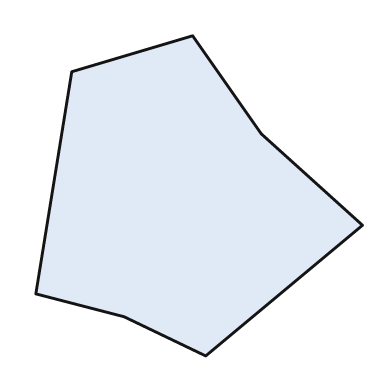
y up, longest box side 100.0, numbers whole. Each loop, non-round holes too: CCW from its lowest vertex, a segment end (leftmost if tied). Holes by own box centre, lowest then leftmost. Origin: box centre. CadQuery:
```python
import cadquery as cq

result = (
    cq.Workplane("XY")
    .moveTo(2.0, -49.0)
    .lineTo(50.0, -9.0)
    .lineTo(19.0, 19.0)
    .lineTo(-2.0, 49.0)
    .lineTo(-39.0, 38.0)
    .lineTo(-50.0, -30.0)
    .lineTo(-23.0, -37.0)
    .close()
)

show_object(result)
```